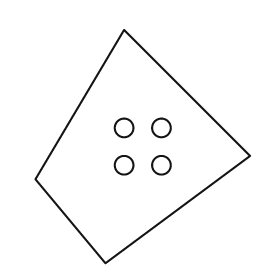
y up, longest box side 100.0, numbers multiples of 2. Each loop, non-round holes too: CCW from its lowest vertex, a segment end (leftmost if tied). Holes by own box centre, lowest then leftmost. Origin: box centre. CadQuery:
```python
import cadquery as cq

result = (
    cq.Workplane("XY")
    .moveTo(-16.0, -50.0)
    .lineTo(46.0, -4.0)
    .lineTo(-8.0, 50.0)
    .lineTo(-46.0, -14.0)
    .close()
    .moveTo(-8.0, -8.0)
    .circle(4.0)
    .moveTo(8.0, -8.0)
    .circle(4.0)
    .moveTo(-8.0, 8.0)
    .circle(4.0)
    .moveTo(8.0, 8.0)
    .circle(4.0)
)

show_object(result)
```